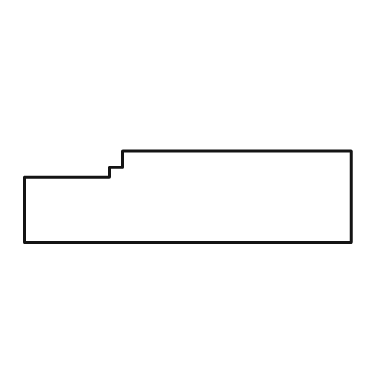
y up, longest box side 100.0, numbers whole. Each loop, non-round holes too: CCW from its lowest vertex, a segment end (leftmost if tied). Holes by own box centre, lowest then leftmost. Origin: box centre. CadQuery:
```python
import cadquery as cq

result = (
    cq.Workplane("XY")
    .moveTo(-50.0, -14.0)
    .lineTo(50.0, -14.0)
    .lineTo(50.0, 14.0)
    .lineTo(-20.0, 14.0)
    .lineTo(-20.0, 9.0)
    .lineTo(-24.0, 9.0)
    .lineTo(-24.0, 6.0)
    .lineTo(-50.0, 6.0)
    .close()
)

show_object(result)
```